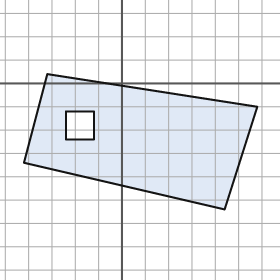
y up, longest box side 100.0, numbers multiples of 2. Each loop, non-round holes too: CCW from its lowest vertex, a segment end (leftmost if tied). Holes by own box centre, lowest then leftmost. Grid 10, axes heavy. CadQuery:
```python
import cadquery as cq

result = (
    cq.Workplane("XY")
    .moveTo(44.0, -54.0)
    .lineTo(58.0, -10.0)
    .lineTo(-32.0, 4.0)
    .lineTo(-42.0, -34.0)
    .close()
    .moveTo(-24.0, -24.0)
    .lineTo(-12.0, -24.0)
    .lineTo(-12.0, -12.0)
    .lineTo(-24.0, -12.0)
    .close()
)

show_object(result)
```